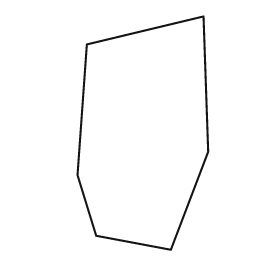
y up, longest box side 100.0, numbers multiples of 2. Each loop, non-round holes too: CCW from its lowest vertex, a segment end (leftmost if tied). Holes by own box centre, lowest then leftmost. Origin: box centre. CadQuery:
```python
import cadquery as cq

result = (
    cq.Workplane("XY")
    .moveTo(12.0, -50.0)
    .lineTo(28.0, -8.0)
    .lineTo(26.0, 50.0)
    .lineTo(-24.0, 38.0)
    .lineTo(-28.0, -18.0)
    .lineTo(-20.0, -44.0)
    .close()
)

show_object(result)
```